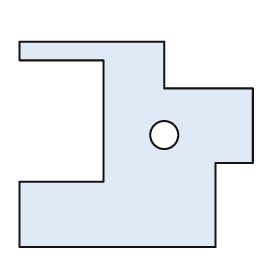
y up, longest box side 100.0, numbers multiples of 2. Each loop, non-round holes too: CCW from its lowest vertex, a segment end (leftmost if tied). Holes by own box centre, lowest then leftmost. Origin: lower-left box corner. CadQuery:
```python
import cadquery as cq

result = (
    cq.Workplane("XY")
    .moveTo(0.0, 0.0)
    .lineTo(84.0, 0.0)
    .lineTo(84.0, 36.0)
    .lineTo(100.0, 36.0)
    .lineTo(100.0, 68.0)
    .lineTo(62.0, 68.0)
    .lineTo(62.0, 88.0)
    .lineTo(0.0, 88.0)
    .lineTo(0.0, 80.0)
    .lineTo(36.0, 80.0)
    .lineTo(36.0, 28.0)
    .lineTo(0.0, 28.0)
    .close()
    .moveTo(62.0, 48.0)
    .circle(6.0)
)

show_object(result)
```